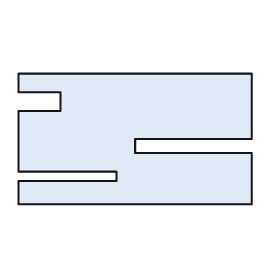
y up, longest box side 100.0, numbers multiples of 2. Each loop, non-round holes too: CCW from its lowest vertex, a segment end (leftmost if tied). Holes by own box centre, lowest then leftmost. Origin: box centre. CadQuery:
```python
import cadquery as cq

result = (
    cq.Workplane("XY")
    .moveTo(-50.0, -28.0)
    .lineTo(50.0, -28.0)
    .lineTo(50.0, -6.0)
    .lineTo(0.0, -6.0)
    .lineTo(0.0, 0.0)
    .lineTo(50.0, 0.0)
    .lineTo(50.0, 28.0)
    .lineTo(-50.0, 28.0)
    .lineTo(-50.0, 20.0)
    .lineTo(-32.0, 20.0)
    .lineTo(-32.0, 12.0)
    .lineTo(-50.0, 12.0)
    .lineTo(-50.0, -14.0)
    .lineTo(-8.0, -14.0)
    .lineTo(-8.0, -18.0)
    .lineTo(-50.0, -18.0)
    .close()
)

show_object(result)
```